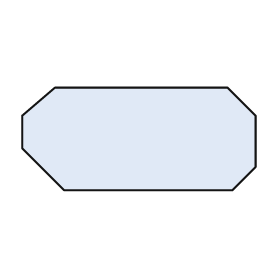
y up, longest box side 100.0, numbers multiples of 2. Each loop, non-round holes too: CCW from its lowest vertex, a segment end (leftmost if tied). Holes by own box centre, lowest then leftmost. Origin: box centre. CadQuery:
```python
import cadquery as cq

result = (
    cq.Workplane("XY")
    .moveTo(-32.0, -22.0)
    .lineTo(40.0, -22.0)
    .lineTo(50.0, -12.0)
    .lineTo(50.0, 10.0)
    .lineTo(38.0, 22.0)
    .lineTo(-36.0, 22.0)
    .lineTo(-50.0, 10.0)
    .lineTo(-50.0, -4.0)
    .close()
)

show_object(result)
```